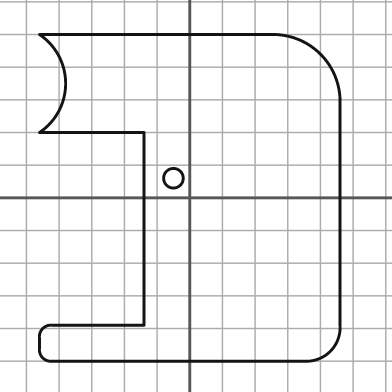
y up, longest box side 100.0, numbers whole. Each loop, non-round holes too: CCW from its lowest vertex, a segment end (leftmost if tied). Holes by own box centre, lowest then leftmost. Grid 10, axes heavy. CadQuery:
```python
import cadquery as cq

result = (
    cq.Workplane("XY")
    .moveTo(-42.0, -50.0)
    .lineTo(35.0, -50.0)
    .threePointArc((43.0, -47.0), (46.0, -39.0))
    .lineTo(46.0, 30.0)
    .threePointArc((40.0, 44.0), (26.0, 50.0))
    .lineTo(-46.0, 50.0)
    .threePointArc((-38.0, 35.0), (-46.0, 20.0))
    .lineTo(-14.0, 20.0)
    .lineTo(-14.0, -39.0)
    .lineTo(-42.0, -39.0)
    .threePointArc((-45.0, -40.0), (-46.0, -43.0))
    .lineTo(-46.0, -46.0)
    .threePointArc((-45.0, -49.0), (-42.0, -50.0))
    .close()
    .moveTo(-5.0, 6.0)
    .circle(3.0)
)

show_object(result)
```